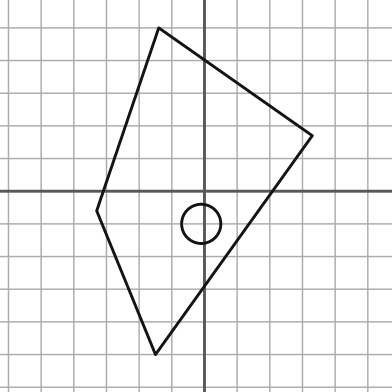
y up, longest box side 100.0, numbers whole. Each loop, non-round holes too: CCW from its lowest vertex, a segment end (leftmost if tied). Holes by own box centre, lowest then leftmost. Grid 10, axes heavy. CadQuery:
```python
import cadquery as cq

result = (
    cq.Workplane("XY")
    .moveTo(-15.0, -50.0)
    .lineTo(33.0, 17.0)
    .lineTo(-14.0, 50.0)
    .lineTo(-33.0, -6.0)
    .close()
    .moveTo(-1.0, -10.0)
    .circle(6.0)
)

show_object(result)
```